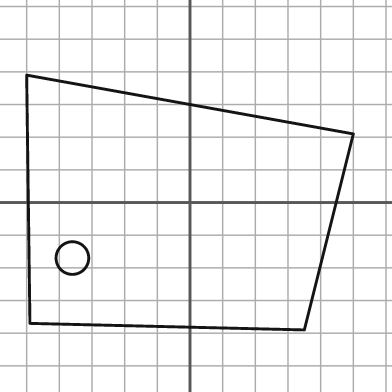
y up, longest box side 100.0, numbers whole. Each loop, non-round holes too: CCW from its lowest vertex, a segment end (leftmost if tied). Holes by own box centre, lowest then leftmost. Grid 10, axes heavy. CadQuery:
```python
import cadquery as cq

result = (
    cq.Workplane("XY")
    .moveTo(35.0, -39.0)
    .lineTo(50.0, 21.0)
    .lineTo(-50.0, 39.0)
    .lineTo(-49.0, -37.0)
    .close()
    .moveTo(-36.0, -17.0)
    .circle(5.0)
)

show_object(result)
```